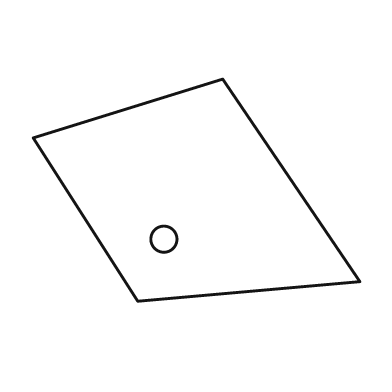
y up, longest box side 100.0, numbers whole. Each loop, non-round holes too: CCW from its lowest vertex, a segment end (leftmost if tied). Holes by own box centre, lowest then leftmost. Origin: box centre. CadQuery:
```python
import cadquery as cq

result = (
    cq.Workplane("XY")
    .moveTo(-18.0, -34.0)
    .lineTo(50.0, -28.0)
    .lineTo(8.0, 34.0)
    .lineTo(-50.0, 16.0)
    .close()
    .moveTo(-10.0, -15.0)
    .circle(4.0)
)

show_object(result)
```